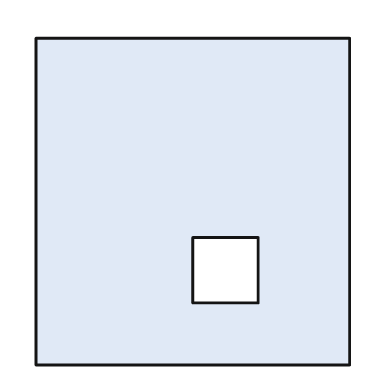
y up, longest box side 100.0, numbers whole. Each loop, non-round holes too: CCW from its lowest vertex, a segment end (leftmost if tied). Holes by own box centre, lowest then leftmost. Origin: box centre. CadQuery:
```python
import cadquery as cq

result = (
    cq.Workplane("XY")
    .moveTo(-48.0, -50.0)
    .lineTo(48.0, -50.0)
    .lineTo(48.0, 50.0)
    .lineTo(-48.0, 50.0)
    .close()
    .moveTo(0.0, -31.0)
    .lineTo(20.0, -31.0)
    .lineTo(20.0, -11.0)
    .lineTo(0.0, -11.0)
    .close()
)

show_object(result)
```